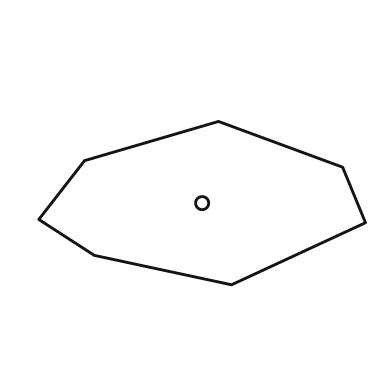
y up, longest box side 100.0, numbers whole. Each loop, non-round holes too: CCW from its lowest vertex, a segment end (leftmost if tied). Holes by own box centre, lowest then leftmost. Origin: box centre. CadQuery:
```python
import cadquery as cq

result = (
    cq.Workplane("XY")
    .moveTo(9.0, -25.0)
    .lineTo(50.0, -6.0)
    .lineTo(43.0, 11.0)
    .lineTo(5.0, 25.0)
    .lineTo(-36.0, 13.0)
    .lineTo(-50.0, -5.0)
    .lineTo(-33.0, -16.0)
    .close()
    .moveTo(0.0, 0.0)
    .circle(2.0)
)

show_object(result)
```